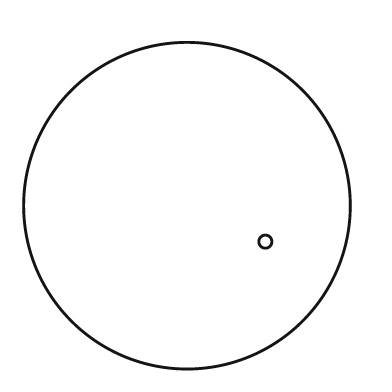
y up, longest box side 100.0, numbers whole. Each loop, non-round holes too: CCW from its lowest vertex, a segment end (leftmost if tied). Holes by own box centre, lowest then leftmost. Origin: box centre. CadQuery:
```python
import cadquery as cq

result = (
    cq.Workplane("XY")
    .moveTo(0.0, 0.0)
    .circle(50.0)
    .moveTo(24.0, -11.0)
    .circle(2.0)
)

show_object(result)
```